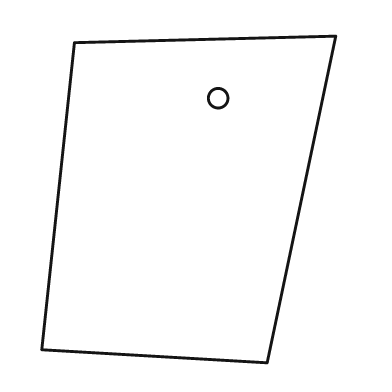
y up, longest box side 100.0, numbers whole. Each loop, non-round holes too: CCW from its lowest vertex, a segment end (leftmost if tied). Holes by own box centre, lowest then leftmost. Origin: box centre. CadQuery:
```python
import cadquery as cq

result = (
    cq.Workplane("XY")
    .moveTo(24.0, -50.0)
    .lineTo(45.0, 50.0)
    .lineTo(-35.0, 48.0)
    .lineTo(-45.0, -46.0)
    .close()
    .moveTo(9.0, 31.0)
    .circle(3.0)
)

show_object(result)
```